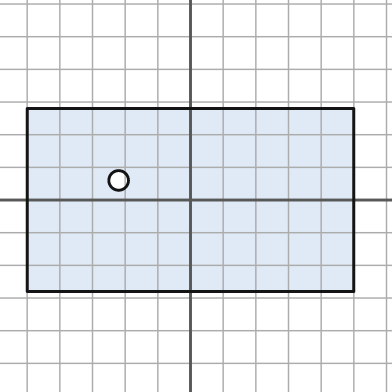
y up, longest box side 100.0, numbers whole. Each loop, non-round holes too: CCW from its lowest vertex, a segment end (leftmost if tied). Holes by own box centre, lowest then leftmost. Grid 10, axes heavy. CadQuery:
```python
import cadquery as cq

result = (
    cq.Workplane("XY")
    .moveTo(-50.0, -28.0)
    .lineTo(50.0, -28.0)
    .lineTo(50.0, 28.0)
    .lineTo(-50.0, 28.0)
    .close()
    .moveTo(-22.0, 6.0)
    .circle(3.0)
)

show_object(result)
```